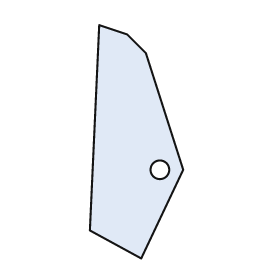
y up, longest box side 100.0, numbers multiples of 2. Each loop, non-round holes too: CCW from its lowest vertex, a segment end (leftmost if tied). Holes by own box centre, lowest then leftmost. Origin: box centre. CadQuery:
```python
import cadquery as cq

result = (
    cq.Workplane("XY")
    .moveTo(2.0, -50.0)
    .lineTo(20.0, -12.0)
    .lineTo(4.0, 38.0)
    .lineTo(-4.0, 46.0)
    .lineTo(-16.0, 50.0)
    .lineTo(-20.0, -38.0)
    .close()
    .moveTo(10.0, -12.0)
    .circle(4.0)
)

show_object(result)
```